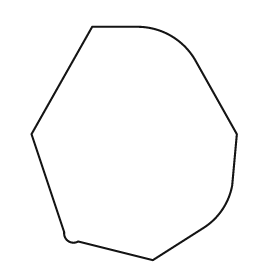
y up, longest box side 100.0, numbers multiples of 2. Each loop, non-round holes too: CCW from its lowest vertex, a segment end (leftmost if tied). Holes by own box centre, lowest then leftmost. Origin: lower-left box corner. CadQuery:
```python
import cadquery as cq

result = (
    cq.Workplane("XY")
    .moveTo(52.0, 0.0)
    .lineTo(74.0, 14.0)
    .threePointArc((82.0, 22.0), (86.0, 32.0))
    .lineTo(88.0, 54.0)
    .lineTo(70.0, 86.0)
    .threePointArc((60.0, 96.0), (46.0, 100.0))
    .lineTo(26.0, 100.0)
    .lineTo(0.0, 54.0)
    .lineTo(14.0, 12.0)
    .threePointArc((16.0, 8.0), (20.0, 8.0))
    .close()
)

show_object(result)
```